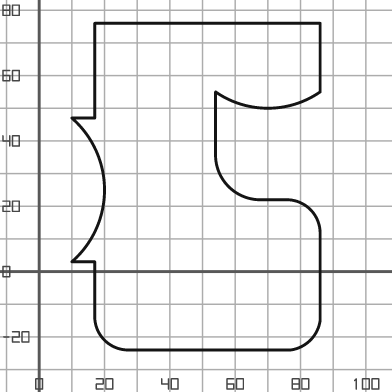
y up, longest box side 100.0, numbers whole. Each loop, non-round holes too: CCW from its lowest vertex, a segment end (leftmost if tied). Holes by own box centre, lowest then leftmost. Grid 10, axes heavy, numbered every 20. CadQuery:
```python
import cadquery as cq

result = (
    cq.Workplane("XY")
    .moveTo(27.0, -24.0)
    .lineTo(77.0, -24.0)
    .threePointArc((83.0, -21.0), (86.0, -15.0))
    .lineTo(86.0, 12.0)
    .threePointArc((83.0, 19.0), (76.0, 22.0))
    .lineTo(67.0, 22.0)
    .threePointArc((58.0, 26.0), (54.0, 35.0))
    .lineTo(54.0, 55.0)
    .threePointArc((70.0, 50.0), (86.0, 55.0))
    .lineTo(86.0, 76.0)
    .lineTo(17.0, 76.0)
    .lineTo(17.0, 47.0)
    .lineTo(10.0, 47.0)
    .threePointArc((20.0, 25.0), (10.0, 3.0))
    .lineTo(17.0, 3.0)
    .lineTo(17.0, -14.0)
    .threePointArc((20.0, -21.0), (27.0, -24.0))
    .close()
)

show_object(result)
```